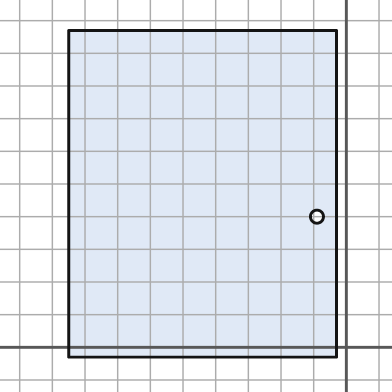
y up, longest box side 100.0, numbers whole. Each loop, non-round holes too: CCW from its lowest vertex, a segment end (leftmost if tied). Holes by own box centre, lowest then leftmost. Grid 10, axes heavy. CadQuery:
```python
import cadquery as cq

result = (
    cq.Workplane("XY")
    .moveTo(-85.0, -3.0)
    .lineTo(-3.0, -3.0)
    .lineTo(-3.0, 97.0)
    .lineTo(-85.0, 97.0)
    .close()
    .moveTo(-9.0, 40.0)
    .circle(2.0)
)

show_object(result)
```